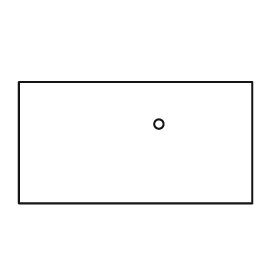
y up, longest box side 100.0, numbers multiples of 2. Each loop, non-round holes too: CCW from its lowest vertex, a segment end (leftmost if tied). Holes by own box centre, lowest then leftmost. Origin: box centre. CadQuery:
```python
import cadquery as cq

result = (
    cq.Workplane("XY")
    .moveTo(-50.0, -26.0)
    .lineTo(50.0, -26.0)
    .lineTo(50.0, 26.0)
    .lineTo(-50.0, 26.0)
    .close()
    .moveTo(10.0, 8.0)
    .circle(2.0)
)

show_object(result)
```